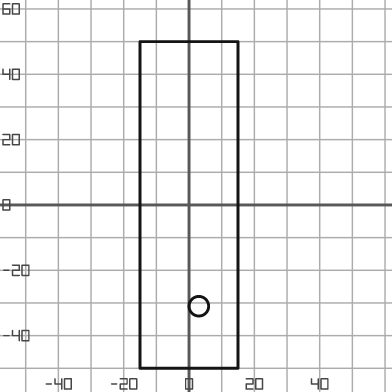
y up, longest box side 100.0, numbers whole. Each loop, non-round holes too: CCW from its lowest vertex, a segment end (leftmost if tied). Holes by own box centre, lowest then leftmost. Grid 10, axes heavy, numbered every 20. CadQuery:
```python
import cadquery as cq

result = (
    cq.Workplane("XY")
    .moveTo(-15.0, -50.0)
    .lineTo(15.0, -50.0)
    .lineTo(15.0, 50.0)
    .lineTo(-15.0, 50.0)
    .close()
    .moveTo(3.0, -31.0)
    .circle(3.0)
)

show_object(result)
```